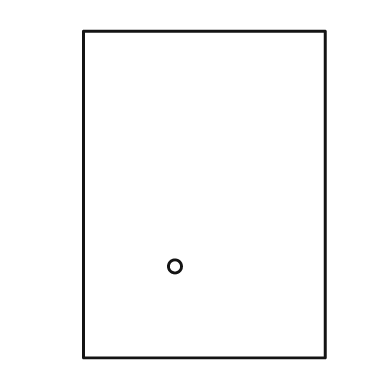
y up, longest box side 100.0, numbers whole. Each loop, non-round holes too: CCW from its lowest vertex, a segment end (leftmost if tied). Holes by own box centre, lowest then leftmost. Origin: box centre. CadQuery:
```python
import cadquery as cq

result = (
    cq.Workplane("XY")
    .moveTo(-37.0, -50.0)
    .lineTo(37.0, -50.0)
    .lineTo(37.0, 50.0)
    .lineTo(-37.0, 50.0)
    .close()
    .moveTo(-9.0, -22.0)
    .circle(2.0)
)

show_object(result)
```